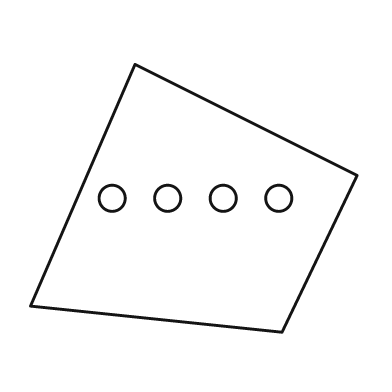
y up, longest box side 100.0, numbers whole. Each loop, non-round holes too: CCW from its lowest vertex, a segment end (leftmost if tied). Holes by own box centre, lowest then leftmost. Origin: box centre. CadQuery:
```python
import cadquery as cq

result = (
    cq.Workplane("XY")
    .moveTo(27.0, -41.0)
    .lineTo(50.0, 7.0)
    .lineTo(-18.0, 41.0)
    .lineTo(-50.0, -33.0)
    .close()
    .moveTo(-25.0, 0.0)
    .circle(4.0)
    .moveTo(-8.0, 0.0)
    .circle(4.0)
    .moveTo(9.0, 0.0)
    .circle(4.0)
    .moveTo(26.0, 0.0)
    .circle(4.0)
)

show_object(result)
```